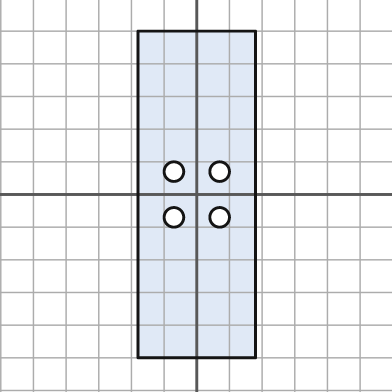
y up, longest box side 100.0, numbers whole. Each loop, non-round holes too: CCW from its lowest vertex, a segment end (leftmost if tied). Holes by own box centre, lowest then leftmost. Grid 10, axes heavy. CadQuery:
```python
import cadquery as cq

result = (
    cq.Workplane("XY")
    .moveTo(-18.0, -50.0)
    .lineTo(18.0, -50.0)
    .lineTo(18.0, 50.0)
    .lineTo(-18.0, 50.0)
    .close()
    .moveTo(-7.0, -7.0)
    .circle(3.0)
    .moveTo(7.0, -7.0)
    .circle(3.0)
    .moveTo(-7.0, 7.0)
    .circle(3.0)
    .moveTo(7.0, 7.0)
    .circle(3.0)
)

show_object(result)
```